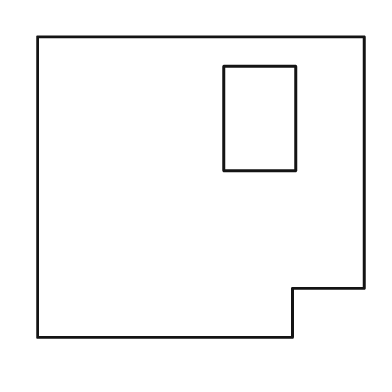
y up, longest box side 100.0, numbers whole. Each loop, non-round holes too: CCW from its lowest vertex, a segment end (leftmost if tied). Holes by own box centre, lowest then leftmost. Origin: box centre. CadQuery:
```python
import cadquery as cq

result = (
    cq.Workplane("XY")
    .moveTo(-50.0, -46.0)
    .lineTo(28.0, -46.0)
    .lineTo(28.0, -31.0)
    .lineTo(50.0, -31.0)
    .lineTo(50.0, 46.0)
    .lineTo(-50.0, 46.0)
    .close()
    .moveTo(7.0, 5.0)
    .lineTo(29.0, 5.0)
    .lineTo(29.0, 37.0)
    .lineTo(7.0, 37.0)
    .close()
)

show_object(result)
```